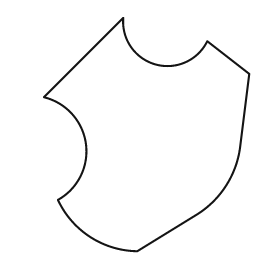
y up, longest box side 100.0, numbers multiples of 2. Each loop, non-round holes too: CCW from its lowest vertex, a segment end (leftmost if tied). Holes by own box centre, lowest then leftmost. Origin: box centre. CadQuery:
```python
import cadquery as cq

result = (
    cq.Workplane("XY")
    .moveTo(-4.0, -50.0)
    .lineTo(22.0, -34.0)
    .threePointArc((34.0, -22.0), (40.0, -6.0))
    .lineTo(44.0, 26.0)
    .lineTo(26.0, 40.0)
    .threePointArc((4.0, 30.0), (-10.0, 50.0))
    .lineTo(-44.0, 16.0)
    .threePointArc((-26.0, -4.0), (-38.0, -28.0))
    .threePointArc((-24.0, -44.0), (-4.0, -50.0))
    .close()
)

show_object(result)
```